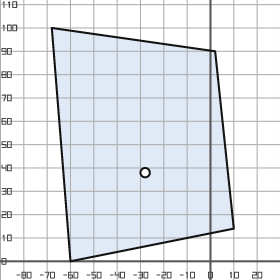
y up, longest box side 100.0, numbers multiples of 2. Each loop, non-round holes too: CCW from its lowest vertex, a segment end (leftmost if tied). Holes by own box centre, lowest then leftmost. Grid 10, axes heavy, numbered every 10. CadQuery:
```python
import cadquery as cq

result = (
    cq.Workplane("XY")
    .moveTo(-60.0, 0.0)
    .lineTo(10.0, 14.0)
    .lineTo(2.0, 90.0)
    .lineTo(-68.0, 100.0)
    .close()
    .moveTo(-28.0, 38.0)
    .circle(2.0)
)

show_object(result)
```